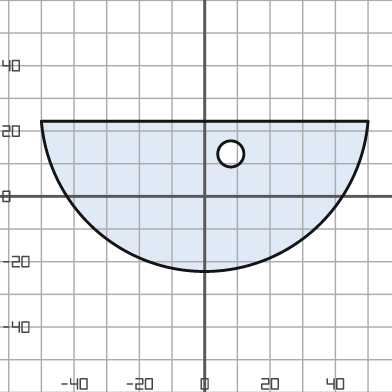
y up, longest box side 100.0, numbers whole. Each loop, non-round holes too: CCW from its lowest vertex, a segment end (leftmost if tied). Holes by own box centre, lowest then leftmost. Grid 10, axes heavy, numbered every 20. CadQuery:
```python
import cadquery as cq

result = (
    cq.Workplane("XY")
    .moveTo(-50.0, 23.0)
    .threePointArc((0.0, -23.0), (50.0, 23.0))
    .close()
    .moveTo(8.0, 13.0)
    .circle(4.0)
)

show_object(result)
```